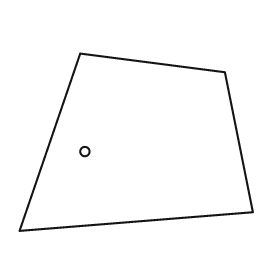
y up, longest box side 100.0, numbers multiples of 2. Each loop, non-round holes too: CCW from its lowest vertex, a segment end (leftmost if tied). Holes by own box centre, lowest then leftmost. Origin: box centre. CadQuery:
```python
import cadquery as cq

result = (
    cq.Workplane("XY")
    .moveTo(-50.0, -38.0)
    .lineTo(50.0, -30.0)
    .lineTo(38.0, 30.0)
    .lineTo(-24.0, 38.0)
    .close()
    .moveTo(-22.0, -4.0)
    .circle(2.0)
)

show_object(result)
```